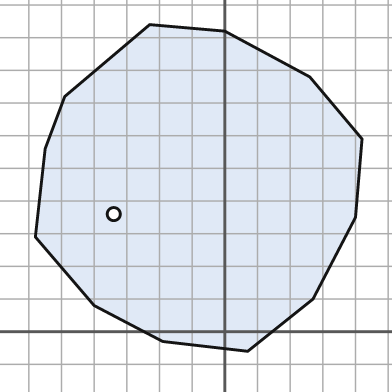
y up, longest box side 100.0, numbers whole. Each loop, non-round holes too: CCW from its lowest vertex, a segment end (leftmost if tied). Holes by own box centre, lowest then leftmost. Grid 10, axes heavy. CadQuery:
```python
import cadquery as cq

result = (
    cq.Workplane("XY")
    .moveTo(7.0, -6.0)
    .lineTo(27.0, 10.0)
    .lineTo(40.0, 35.0)
    .lineTo(42.0, 59.0)
    .lineTo(26.0, 78.0)
    .lineTo(0.0, 92.0)
    .lineTo(-23.0, 94.0)
    .lineTo(-49.0, 72.0)
    .lineTo(-55.0, 56.0)
    .lineTo(-58.0, 29.0)
    .lineTo(-40.0, 8.0)
    .lineTo(-19.0, -3.0)
    .close()
    .moveTo(-34.0, 36.0)
    .circle(2.0)
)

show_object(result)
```